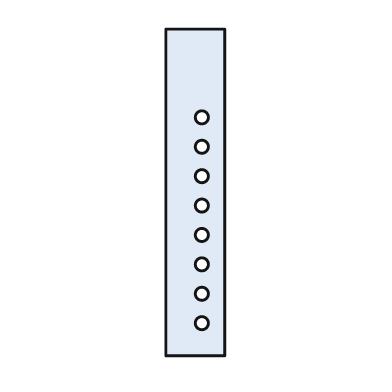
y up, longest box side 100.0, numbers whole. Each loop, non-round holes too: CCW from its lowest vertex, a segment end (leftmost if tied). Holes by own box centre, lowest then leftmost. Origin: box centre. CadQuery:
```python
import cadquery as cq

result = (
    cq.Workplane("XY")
    .moveTo(-9.0, -50.0)
    .lineTo(9.0, -50.0)
    .lineTo(9.0, 50.0)
    .lineTo(-9.0, 50.0)
    .close()
    .moveTo(2.0, -40.0)
    .circle(2.0)
    .moveTo(2.0, -31.0)
    .circle(2.0)
    .moveTo(2.0, -22.0)
    .circle(2.0)
    .moveTo(2.0, -13.0)
    .circle(2.0)
    .moveTo(2.0, -4.0)
    .circle(2.0)
    .moveTo(2.0, 5.0)
    .circle(2.0)
    .moveTo(2.0, 14.0)
    .circle(2.0)
    .moveTo(2.0, 23.0)
    .circle(2.0)
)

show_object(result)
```